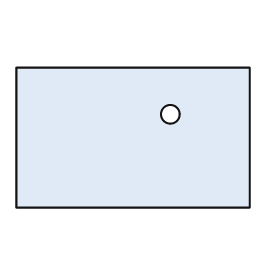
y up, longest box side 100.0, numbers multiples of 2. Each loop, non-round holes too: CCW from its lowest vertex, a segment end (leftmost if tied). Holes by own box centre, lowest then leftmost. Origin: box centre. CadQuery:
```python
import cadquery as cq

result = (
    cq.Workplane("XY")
    .moveTo(-50.0, -30.0)
    .lineTo(50.0, -30.0)
    .lineTo(50.0, 30.0)
    .lineTo(-50.0, 30.0)
    .close()
    .moveTo(16.0, 10.0)
    .circle(4.0)
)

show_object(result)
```